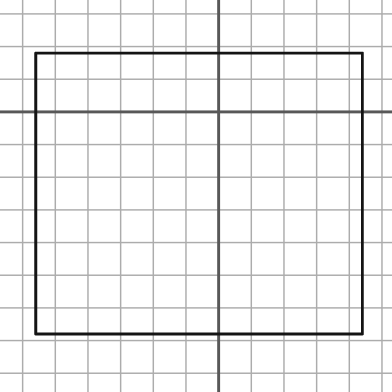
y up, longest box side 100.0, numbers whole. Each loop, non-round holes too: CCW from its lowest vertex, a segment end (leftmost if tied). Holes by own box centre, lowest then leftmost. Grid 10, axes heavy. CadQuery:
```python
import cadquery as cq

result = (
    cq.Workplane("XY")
    .moveTo(-56.0, -68.0)
    .lineTo(44.0, -68.0)
    .lineTo(44.0, 18.0)
    .lineTo(-56.0, 18.0)
    .close()
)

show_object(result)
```